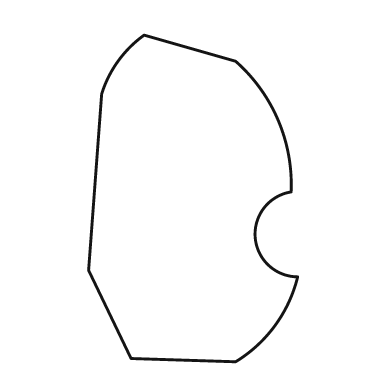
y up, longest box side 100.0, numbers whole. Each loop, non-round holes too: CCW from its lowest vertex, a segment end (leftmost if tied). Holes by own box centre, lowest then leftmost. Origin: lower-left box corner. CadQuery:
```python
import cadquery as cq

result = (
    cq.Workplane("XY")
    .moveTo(45.0, 0.0)
    .threePointArc((57.0, 11.0), (64.0, 26.0))
    .threePointArc((51.0, 38.0), (62.0, 52.0))
    .threePointArc((58.0, 74.0), (45.0, 92.0))
    .lineTo(17.0, 100.0)
    .threePointArc((9.0, 92.0), (4.0, 82.0))
    .lineTo(0.0, 28.0)
    .lineTo(13.0, 1.0)
    .close()
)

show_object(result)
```